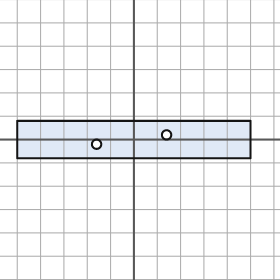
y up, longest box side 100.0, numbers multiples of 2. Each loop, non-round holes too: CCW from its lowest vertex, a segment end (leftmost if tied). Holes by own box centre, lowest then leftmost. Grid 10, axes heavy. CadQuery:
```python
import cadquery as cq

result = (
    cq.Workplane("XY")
    .moveTo(-50.0, -8.0)
    .lineTo(50.0, -8.0)
    .lineTo(50.0, 8.0)
    .lineTo(-50.0, 8.0)
    .close()
    .moveTo(-16.0, -2.0)
    .circle(2.0)
    .moveTo(14.0, 2.0)
    .circle(2.0)
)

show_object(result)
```